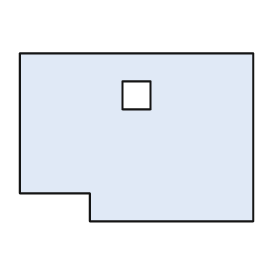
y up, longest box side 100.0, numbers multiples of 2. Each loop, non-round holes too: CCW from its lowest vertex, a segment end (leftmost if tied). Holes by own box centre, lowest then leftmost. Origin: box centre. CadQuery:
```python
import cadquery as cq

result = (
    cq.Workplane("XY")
    .moveTo(-20.0, -36.0)
    .lineTo(50.0, -36.0)
    .lineTo(50.0, 36.0)
    .lineTo(-50.0, 36.0)
    .lineTo(-50.0, -24.0)
    .lineTo(-20.0, -24.0)
    .close()
    .moveTo(-6.0, 12.0)
    .lineTo(6.0, 12.0)
    .lineTo(6.0, 24.0)
    .lineTo(-6.0, 24.0)
    .close()
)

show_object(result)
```